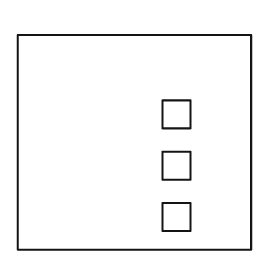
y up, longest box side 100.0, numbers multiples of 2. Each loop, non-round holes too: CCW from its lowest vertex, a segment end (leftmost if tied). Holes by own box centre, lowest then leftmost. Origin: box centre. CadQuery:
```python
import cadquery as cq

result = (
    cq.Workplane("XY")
    .moveTo(-50.0, -46.0)
    .lineTo(50.0, -46.0)
    .lineTo(50.0, 46.0)
    .lineTo(-50.0, 46.0)
    .close()
    .moveTo(12.0, -38.0)
    .lineTo(24.0, -38.0)
    .lineTo(24.0, -26.0)
    .lineTo(12.0, -26.0)
    .close()
    .moveTo(12.0, -16.0)
    .lineTo(24.0, -16.0)
    .lineTo(24.0, -4.0)
    .lineTo(12.0, -4.0)
    .close()
    .moveTo(12.0, 6.0)
    .lineTo(24.0, 6.0)
    .lineTo(24.0, 18.0)
    .lineTo(12.0, 18.0)
    .close()
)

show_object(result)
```